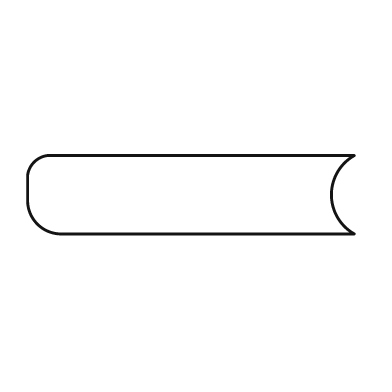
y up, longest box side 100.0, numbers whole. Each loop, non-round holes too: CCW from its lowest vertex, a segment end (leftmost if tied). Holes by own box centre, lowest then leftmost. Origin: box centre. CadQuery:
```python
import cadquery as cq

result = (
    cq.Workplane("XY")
    .moveTo(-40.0, -12.0)
    .lineTo(50.0, -12.0)
    .threePointArc((43.0, 0.0), (50.0, 12.0))
    .lineTo(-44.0, 12.0)
    .threePointArc((-48.0, 10.0), (-50.0, 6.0))
    .lineTo(-50.0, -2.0)
    .threePointArc((-47.0, -9.0), (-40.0, -12.0))
    .close()
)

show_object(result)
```